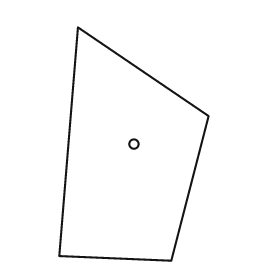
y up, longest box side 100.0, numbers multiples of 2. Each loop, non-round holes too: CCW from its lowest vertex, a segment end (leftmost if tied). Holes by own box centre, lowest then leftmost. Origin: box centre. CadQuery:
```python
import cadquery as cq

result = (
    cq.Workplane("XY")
    .moveTo(16.0, -50.0)
    .lineTo(32.0, 12.0)
    .lineTo(-24.0, 50.0)
    .lineTo(-32.0, -48.0)
    .close()
    .moveTo(0.0, 0.0)
    .circle(2.0)
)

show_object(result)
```